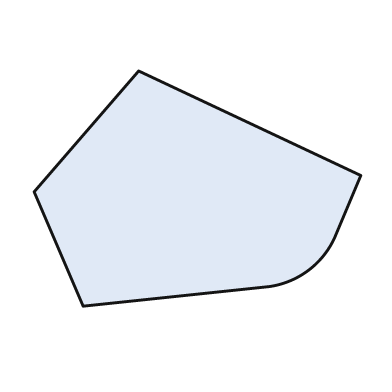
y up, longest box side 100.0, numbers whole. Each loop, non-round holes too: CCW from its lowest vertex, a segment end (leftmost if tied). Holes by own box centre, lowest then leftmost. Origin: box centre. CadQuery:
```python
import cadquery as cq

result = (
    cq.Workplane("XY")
    .moveTo(-35.0, -36.0)
    .lineTo(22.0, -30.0)
    .threePointArc((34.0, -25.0), (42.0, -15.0))
    .lineTo(50.0, 4.0)
    .lineTo(-18.0, 36.0)
    .lineTo(-50.0, -1.0)
    .close()
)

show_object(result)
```